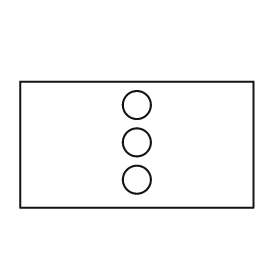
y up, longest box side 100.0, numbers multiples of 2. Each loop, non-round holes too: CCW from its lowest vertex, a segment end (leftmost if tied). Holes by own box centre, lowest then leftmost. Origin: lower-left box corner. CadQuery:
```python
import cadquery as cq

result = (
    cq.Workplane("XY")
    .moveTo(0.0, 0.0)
    .lineTo(100.0, 0.0)
    .lineTo(100.0, 54.0)
    .lineTo(0.0, 54.0)
    .close()
    .moveTo(50.0, 12.0)
    .circle(6.0)
    .moveTo(50.0, 28.0)
    .circle(6.0)
    .moveTo(50.0, 44.0)
    .circle(6.0)
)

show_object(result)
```